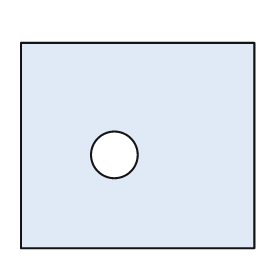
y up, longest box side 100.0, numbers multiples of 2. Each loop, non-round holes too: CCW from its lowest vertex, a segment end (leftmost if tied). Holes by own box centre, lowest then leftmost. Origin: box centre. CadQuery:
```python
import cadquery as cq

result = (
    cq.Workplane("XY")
    .moveTo(-50.0, -44.0)
    .lineTo(50.0, -44.0)
    .lineTo(50.0, 44.0)
    .lineTo(-50.0, 44.0)
    .close()
    .moveTo(-10.0, -4.0)
    .circle(10.0)
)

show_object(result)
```